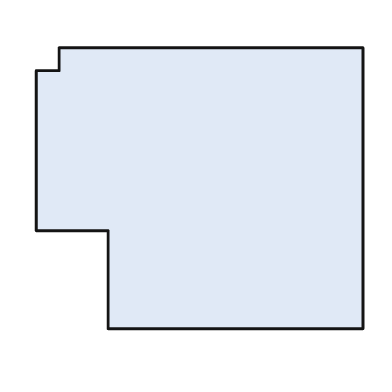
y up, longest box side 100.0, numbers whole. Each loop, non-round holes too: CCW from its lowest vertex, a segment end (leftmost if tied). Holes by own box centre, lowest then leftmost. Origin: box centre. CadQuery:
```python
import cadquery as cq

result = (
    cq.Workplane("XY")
    .moveTo(-28.0, -43.0)
    .lineTo(50.0, -43.0)
    .lineTo(50.0, 43.0)
    .lineTo(-43.0, 43.0)
    .lineTo(-43.0, 36.0)
    .lineTo(-50.0, 36.0)
    .lineTo(-50.0, -13.0)
    .lineTo(-28.0, -13.0)
    .close()
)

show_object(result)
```